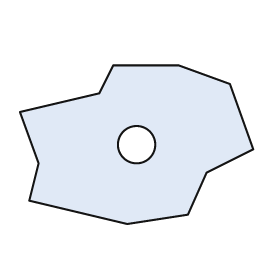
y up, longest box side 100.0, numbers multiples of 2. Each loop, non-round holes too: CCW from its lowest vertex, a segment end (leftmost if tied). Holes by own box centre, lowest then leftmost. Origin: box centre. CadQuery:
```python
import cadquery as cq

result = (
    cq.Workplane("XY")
    .moveTo(-4.0, -34.0)
    .lineTo(22.0, -30.0)
    .lineTo(30.0, -12.0)
    .lineTo(50.0, -2.0)
    .lineTo(40.0, 26.0)
    .lineTo(18.0, 34.0)
    .lineTo(-10.0, 34.0)
    .lineTo(-16.0, 22.0)
    .lineTo(-50.0, 14.0)
    .lineTo(-42.0, -8.0)
    .lineTo(-46.0, -24.0)
    .close()
    .moveTo(0.0, 0.0)
    .circle(8.0)
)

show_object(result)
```